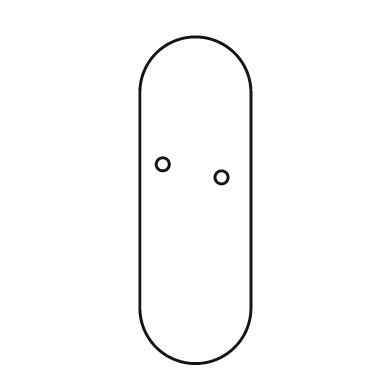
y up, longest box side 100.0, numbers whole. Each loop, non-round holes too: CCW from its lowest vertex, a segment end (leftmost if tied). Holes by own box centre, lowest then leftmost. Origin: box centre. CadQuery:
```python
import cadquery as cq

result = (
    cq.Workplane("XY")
    .moveTo(-17.0, -33.0)
    .threePointArc((0.0, -50.0), (17.0, -33.0))
    .lineTo(17.0, 33.0)
    .threePointArc((0.0, 50.0), (-17.0, 33.0))
    .close()
    .moveTo(8.0, 7.0)
    .circle(2.0)
    .moveTo(-10.0, 11.0)
    .circle(2.0)
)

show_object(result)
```